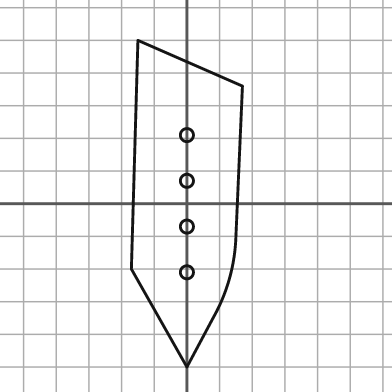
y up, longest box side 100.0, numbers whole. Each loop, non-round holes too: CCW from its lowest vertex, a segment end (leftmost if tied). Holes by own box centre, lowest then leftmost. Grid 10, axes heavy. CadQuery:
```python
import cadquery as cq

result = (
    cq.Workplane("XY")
    .moveTo(0.0, -50.0)
    .lineTo(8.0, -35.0)
    .threePointArc((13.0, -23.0), (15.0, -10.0))
    .lineTo(17.0, 36.0)
    .lineTo(-15.0, 50.0)
    .lineTo(-17.0, -20.0)
    .close()
    .moveTo(0.0, -21.0)
    .circle(2.0)
    .moveTo(0.0, -7.0)
    .circle(2.0)
    .moveTo(0.0, 7.0)
    .circle(2.0)
    .moveTo(0.0, 21.0)
    .circle(2.0)
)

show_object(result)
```